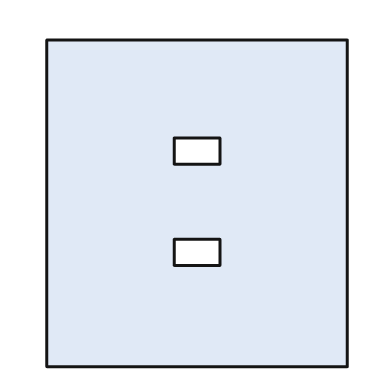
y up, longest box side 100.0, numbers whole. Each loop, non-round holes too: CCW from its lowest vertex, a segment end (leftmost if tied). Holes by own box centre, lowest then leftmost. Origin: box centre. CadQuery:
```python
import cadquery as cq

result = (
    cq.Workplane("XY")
    .moveTo(-46.0, -50.0)
    .lineTo(46.0, -50.0)
    .lineTo(46.0, 50.0)
    .lineTo(-46.0, 50.0)
    .close()
    .moveTo(-7.0, -19.0)
    .lineTo(7.0, -19.0)
    .lineTo(7.0, -11.0)
    .lineTo(-7.0, -11.0)
    .close()
    .moveTo(-7.0, 12.0)
    .lineTo(7.0, 12.0)
    .lineTo(7.0, 20.0)
    .lineTo(-7.0, 20.0)
    .close()
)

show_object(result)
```